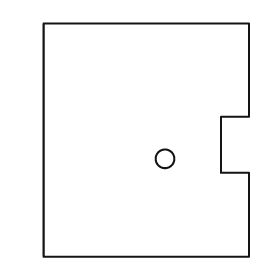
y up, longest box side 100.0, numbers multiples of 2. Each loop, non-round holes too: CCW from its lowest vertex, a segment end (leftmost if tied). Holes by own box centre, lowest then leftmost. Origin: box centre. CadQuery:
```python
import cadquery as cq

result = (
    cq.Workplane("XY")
    .moveTo(-44.0, -50.0)
    .lineTo(44.0, -50.0)
    .lineTo(44.0, -14.0)
    .lineTo(32.0, -14.0)
    .lineTo(32.0, 10.0)
    .lineTo(44.0, 10.0)
    .lineTo(44.0, 50.0)
    .lineTo(-44.0, 50.0)
    .close()
    .moveTo(8.0, -8.0)
    .circle(4.0)
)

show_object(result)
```